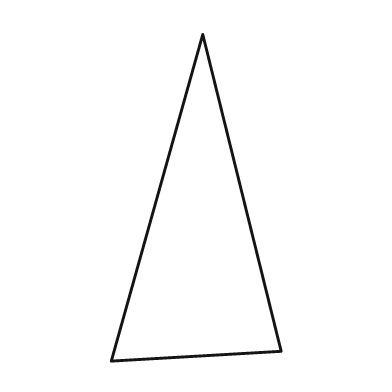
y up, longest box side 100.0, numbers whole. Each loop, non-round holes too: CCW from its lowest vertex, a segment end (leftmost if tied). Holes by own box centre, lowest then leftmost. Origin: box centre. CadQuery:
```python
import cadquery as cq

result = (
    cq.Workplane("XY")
    .moveTo(-26.0, -50.0)
    .lineTo(26.0, -47.0)
    .lineTo(2.0, 50.0)
    .close()
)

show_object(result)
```